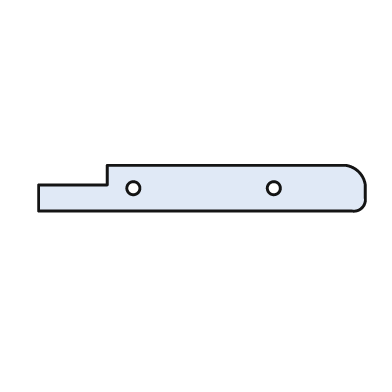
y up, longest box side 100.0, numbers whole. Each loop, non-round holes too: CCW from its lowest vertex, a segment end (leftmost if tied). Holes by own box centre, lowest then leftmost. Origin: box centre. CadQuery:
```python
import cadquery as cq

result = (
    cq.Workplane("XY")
    .moveTo(-50.0, -7.0)
    .lineTo(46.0, -7.0)
    .threePointArc((49.0, -6.0), (50.0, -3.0))
    .lineTo(50.0, 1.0)
    .threePointArc((48.0, 5.0), (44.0, 7.0))
    .lineTo(-29.0, 7.0)
    .lineTo(-29.0, 1.0)
    .lineTo(-50.0, 1.0)
    .close()
    .moveTo(-21.0, 0.0)
    .circle(2.0)
    .moveTo(22.0, 0.0)
    .circle(2.0)
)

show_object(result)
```